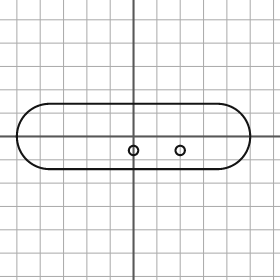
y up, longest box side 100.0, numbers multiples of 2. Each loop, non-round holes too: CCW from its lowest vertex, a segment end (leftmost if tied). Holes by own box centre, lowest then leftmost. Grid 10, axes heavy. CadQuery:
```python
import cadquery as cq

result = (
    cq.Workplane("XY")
    .moveTo(-36.0, -14.0)
    .lineTo(36.0, -14.0)
    .threePointArc((50.0, 0.0), (36.0, 14.0))
    .lineTo(-36.0, 14.0)
    .threePointArc((-50.0, 0.0), (-36.0, -14.0))
    .close()
    .moveTo(0.0, -6.0)
    .circle(2.0)
    .moveTo(20.0, -6.0)
    .circle(2.0)
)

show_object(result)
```